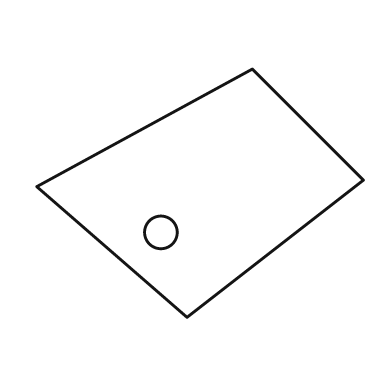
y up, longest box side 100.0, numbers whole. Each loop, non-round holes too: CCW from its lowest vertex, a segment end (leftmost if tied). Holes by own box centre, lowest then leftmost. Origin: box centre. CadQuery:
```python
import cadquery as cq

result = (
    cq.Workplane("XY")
    .moveTo(-4.0, -38.0)
    .lineTo(50.0, 4.0)
    .lineTo(16.0, 38.0)
    .lineTo(-50.0, 2.0)
    .close()
    .moveTo(-12.0, -12.0)
    .circle(5.0)
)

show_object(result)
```